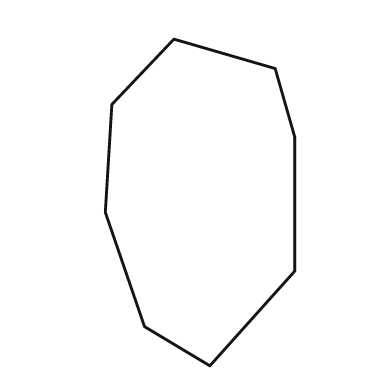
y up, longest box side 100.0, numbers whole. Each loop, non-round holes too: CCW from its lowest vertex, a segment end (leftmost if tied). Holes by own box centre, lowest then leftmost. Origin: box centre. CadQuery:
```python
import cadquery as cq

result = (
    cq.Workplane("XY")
    .moveTo(3.0, -50.0)
    .lineTo(29.0, -21.0)
    .lineTo(29.0, 20.0)
    .lineTo(23.0, 41.0)
    .lineTo(-8.0, 50.0)
    .lineTo(-27.0, 30.0)
    .lineTo(-29.0, -3.0)
    .lineTo(-17.0, -38.0)
    .close()
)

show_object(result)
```